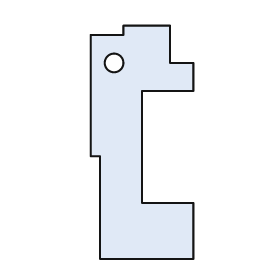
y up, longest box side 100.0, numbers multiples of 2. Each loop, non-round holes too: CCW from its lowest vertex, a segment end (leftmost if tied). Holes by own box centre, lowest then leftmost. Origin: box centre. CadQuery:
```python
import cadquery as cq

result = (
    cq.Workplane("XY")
    .moveTo(-18.0, -50.0)
    .lineTo(22.0, -50.0)
    .lineTo(22.0, -26.0)
    .lineTo(0.0, -26.0)
    .lineTo(0.0, 22.0)
    .lineTo(22.0, 22.0)
    .lineTo(22.0, 34.0)
    .lineTo(12.0, 34.0)
    .lineTo(12.0, 50.0)
    .lineTo(-8.0, 50.0)
    .lineTo(-8.0, 46.0)
    .lineTo(-22.0, 46.0)
    .lineTo(-22.0, -6.0)
    .lineTo(-18.0, -6.0)
    .close()
    .moveTo(-12.0, 34.0)
    .circle(4.0)
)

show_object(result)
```